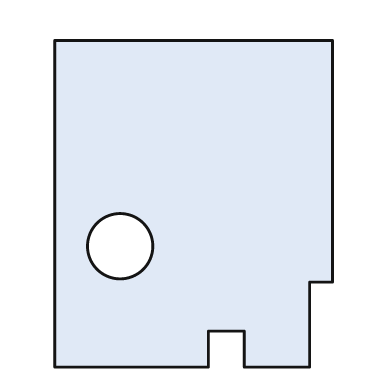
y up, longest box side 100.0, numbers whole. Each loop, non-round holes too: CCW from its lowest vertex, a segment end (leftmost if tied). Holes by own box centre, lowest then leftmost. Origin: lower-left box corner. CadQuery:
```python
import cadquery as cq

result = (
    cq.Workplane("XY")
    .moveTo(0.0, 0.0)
    .lineTo(47.0, 0.0)
    .lineTo(47.0, 11.0)
    .lineTo(58.0, 11.0)
    .lineTo(58.0, 0.0)
    .lineTo(78.0, 0.0)
    .lineTo(78.0, 26.0)
    .lineTo(85.0, 26.0)
    .lineTo(85.0, 100.0)
    .lineTo(0.0, 100.0)
    .close()
    .moveTo(20.0, 37.0)
    .circle(10.0)
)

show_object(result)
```